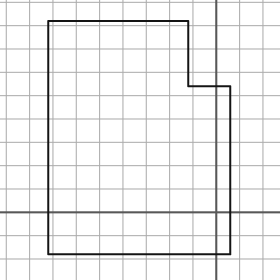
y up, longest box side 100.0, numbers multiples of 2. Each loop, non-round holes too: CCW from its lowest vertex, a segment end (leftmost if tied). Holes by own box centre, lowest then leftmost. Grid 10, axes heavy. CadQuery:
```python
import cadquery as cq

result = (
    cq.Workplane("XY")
    .moveTo(-72.0, -18.0)
    .lineTo(6.0, -18.0)
    .lineTo(6.0, 54.0)
    .lineTo(-12.0, 54.0)
    .lineTo(-12.0, 82.0)
    .lineTo(-72.0, 82.0)
    .close()
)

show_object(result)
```